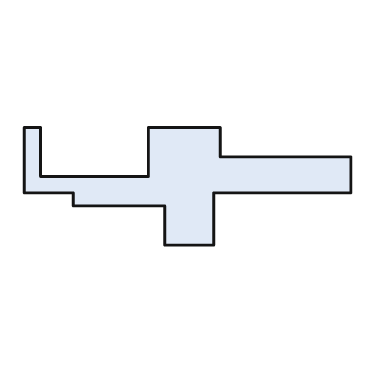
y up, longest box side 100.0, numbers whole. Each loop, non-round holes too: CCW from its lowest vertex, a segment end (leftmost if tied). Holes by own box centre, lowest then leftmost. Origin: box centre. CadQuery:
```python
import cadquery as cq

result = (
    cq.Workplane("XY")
    .moveTo(-7.0, -18.0)
    .lineTo(8.0, -18.0)
    .lineTo(8.0, -2.0)
    .lineTo(50.0, -2.0)
    .lineTo(50.0, 9.0)
    .lineTo(10.0, 9.0)
    .lineTo(10.0, 18.0)
    .lineTo(-12.0, 18.0)
    .lineTo(-12.0, 3.0)
    .lineTo(-45.0, 3.0)
    .lineTo(-45.0, 18.0)
    .lineTo(-50.0, 18.0)
    .lineTo(-50.0, -2.0)
    .lineTo(-35.0, -2.0)
    .lineTo(-35.0, -6.0)
    .lineTo(-7.0, -6.0)
    .close()
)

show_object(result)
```